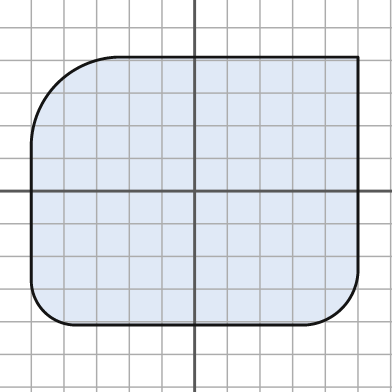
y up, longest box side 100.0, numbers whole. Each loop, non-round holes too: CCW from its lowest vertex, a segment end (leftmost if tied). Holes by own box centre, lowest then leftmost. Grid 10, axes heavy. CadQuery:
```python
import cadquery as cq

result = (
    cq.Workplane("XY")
    .moveTo(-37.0, -41.0)
    .lineTo(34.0, -41.0)
    .threePointArc((45.0, -36.0), (50.0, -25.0))
    .lineTo(50.0, 41.0)
    .lineTo(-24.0, 41.0)
    .threePointArc((-42.0, 33.0), (-50.0, 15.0))
    .lineTo(-50.0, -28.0)
    .threePointArc((-46.0, -37.0), (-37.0, -41.0))
    .close()
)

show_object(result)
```